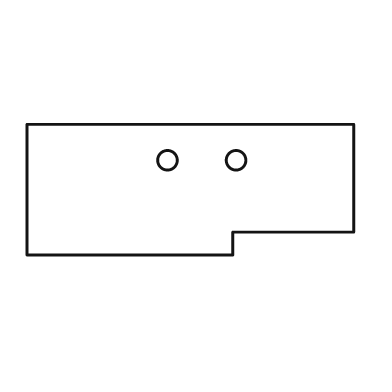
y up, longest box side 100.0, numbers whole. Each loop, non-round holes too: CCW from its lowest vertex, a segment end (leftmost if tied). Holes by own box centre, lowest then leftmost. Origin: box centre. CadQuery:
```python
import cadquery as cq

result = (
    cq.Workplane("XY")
    .moveTo(-50.0, -20.0)
    .lineTo(13.0, -20.0)
    .lineTo(13.0, -13.0)
    .lineTo(50.0, -13.0)
    .lineTo(50.0, 20.0)
    .lineTo(-50.0, 20.0)
    .close()
    .moveTo(-7.0, 9.0)
    .circle(3.0)
    .moveTo(14.0, 9.0)
    .circle(3.0)
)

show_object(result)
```